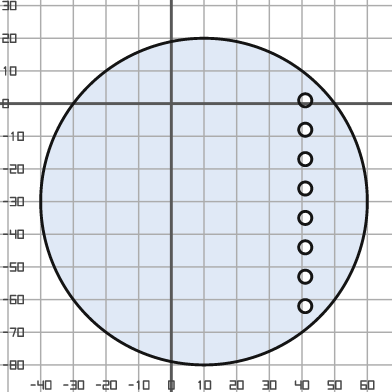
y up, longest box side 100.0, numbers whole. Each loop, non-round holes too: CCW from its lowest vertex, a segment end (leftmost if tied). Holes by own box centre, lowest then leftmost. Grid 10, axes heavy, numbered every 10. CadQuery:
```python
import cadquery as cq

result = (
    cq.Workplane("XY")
    .moveTo(10.0, -30.0)
    .circle(50.0)
    .moveTo(41.0, -62.0)
    .circle(2.0)
    .moveTo(41.0, -53.0)
    .circle(2.0)
    .moveTo(41.0, -44.0)
    .circle(2.0)
    .moveTo(41.0, -35.0)
    .circle(2.0)
    .moveTo(41.0, -26.0)
    .circle(2.0)
    .moveTo(41.0, -17.0)
    .circle(2.0)
    .moveTo(41.0, -8.0)
    .circle(2.0)
    .moveTo(41.0, 1.0)
    .circle(2.0)
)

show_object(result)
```